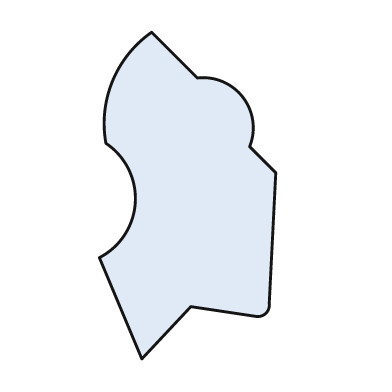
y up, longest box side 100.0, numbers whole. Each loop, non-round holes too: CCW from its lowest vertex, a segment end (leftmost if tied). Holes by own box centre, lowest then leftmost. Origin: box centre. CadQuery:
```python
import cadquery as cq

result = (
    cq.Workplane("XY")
    .moveTo(-14.0, -50.0)
    .lineTo(1.0, -34.0)
    .lineTo(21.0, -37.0)
    .threePointArc((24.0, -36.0), (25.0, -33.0))
    .lineTo(27.0, 7.0)
    .lineTo(19.0, 15.0)
    .threePointArc((17.0, 30.0), (3.0, 36.0))
    .lineTo(-11.0, 50.0)
    .threePointArc((-23.0, 35.0), (-25.0, 16.0))
    .threePointArc((-16.0, -2.0), (-27.0, -19.0))
    .close()
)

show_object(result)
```